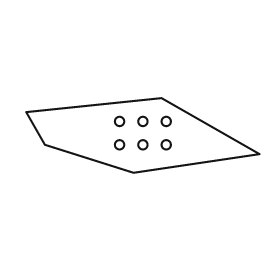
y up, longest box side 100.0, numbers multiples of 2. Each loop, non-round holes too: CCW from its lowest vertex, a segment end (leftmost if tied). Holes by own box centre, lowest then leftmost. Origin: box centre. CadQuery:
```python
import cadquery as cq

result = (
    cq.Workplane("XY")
    .moveTo(-4.0, -16.0)
    .lineTo(50.0, -8.0)
    .lineTo(8.0, 16.0)
    .lineTo(-50.0, 10.0)
    .lineTo(-42.0, -4.0)
    .close()
    .moveTo(-10.0, -4.0)
    .circle(2.0)
    .moveTo(0.0, -4.0)
    .circle(2.0)
    .moveTo(10.0, -4.0)
    .circle(2.0)
    .moveTo(-10.0, 6.0)
    .circle(2.0)
    .moveTo(0.0, 6.0)
    .circle(2.0)
    .moveTo(10.0, 6.0)
    .circle(2.0)
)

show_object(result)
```